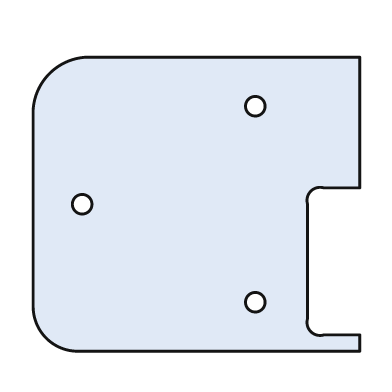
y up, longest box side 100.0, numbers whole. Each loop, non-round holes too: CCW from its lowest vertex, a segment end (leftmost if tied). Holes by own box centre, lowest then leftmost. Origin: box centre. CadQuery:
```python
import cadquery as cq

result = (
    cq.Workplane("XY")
    .moveTo(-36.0, -45.0)
    .lineTo(50.0, -45.0)
    .lineTo(50.0, -40.0)
    .lineTo(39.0, -40.0)
    .threePointArc((35.0, -39.0), (34.0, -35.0))
    .lineTo(34.0, 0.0)
    .threePointArc((35.0, 4.0), (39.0, 5.0))
    .lineTo(50.0, 5.0)
    .lineTo(50.0, 45.0)
    .lineTo(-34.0, 45.0)
    .threePointArc((-45.0, 40.0), (-50.0, 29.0))
    .lineTo(-50.0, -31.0)
    .threePointArc((-46.0, -41.0), (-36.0, -45.0))
    .close()
    .moveTo(18.0, -30.0)
    .circle(3.0)
    .moveTo(-35.0, 0.0)
    .circle(3.0)
    .moveTo(18.0, 30.0)
    .circle(3.0)
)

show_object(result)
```